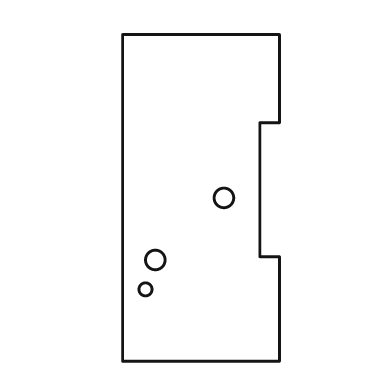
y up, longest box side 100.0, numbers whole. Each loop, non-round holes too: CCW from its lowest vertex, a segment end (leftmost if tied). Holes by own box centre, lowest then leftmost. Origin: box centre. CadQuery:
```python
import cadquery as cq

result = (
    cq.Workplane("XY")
    .moveTo(-24.0, -50.0)
    .lineTo(24.0, -50.0)
    .lineTo(24.0, -18.0)
    .lineTo(18.0, -18.0)
    .lineTo(18.0, 23.0)
    .lineTo(24.0, 23.0)
    .lineTo(24.0, 50.0)
    .lineTo(-24.0, 50.0)
    .close()
    .moveTo(-17.0, -28.0)
    .circle(2.0)
    .moveTo(-14.0, -19.0)
    .circle(3.0)
    .moveTo(7.0, 0.0)
    .circle(3.0)
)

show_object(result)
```